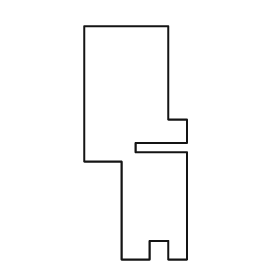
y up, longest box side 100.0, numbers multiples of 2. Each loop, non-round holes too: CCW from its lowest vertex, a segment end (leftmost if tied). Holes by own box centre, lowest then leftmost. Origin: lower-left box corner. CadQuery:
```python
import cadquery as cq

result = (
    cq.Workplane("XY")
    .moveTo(16.0, 0.0)
    .lineTo(28.0, 0.0)
    .lineTo(28.0, 8.0)
    .lineTo(36.0, 8.0)
    .lineTo(36.0, 0.0)
    .lineTo(44.0, 0.0)
    .lineTo(44.0, 46.0)
    .lineTo(22.0, 46.0)
    .lineTo(22.0, 50.0)
    .lineTo(44.0, 50.0)
    .lineTo(44.0, 60.0)
    .lineTo(36.0, 60.0)
    .lineTo(36.0, 100.0)
    .lineTo(0.0, 100.0)
    .lineTo(0.0, 42.0)
    .lineTo(16.0, 42.0)
    .close()
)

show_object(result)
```